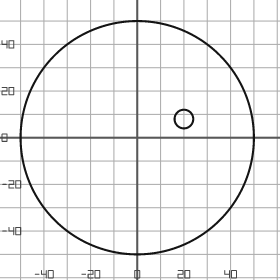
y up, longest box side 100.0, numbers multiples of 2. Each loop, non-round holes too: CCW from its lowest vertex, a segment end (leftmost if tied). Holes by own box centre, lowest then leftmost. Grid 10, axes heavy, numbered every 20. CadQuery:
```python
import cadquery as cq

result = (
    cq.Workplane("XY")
    .moveTo(0.0, 0.0)
    .circle(50.0)
    .moveTo(20.0, 8.0)
    .circle(4.0)
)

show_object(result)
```